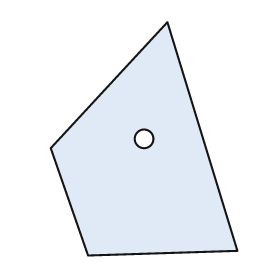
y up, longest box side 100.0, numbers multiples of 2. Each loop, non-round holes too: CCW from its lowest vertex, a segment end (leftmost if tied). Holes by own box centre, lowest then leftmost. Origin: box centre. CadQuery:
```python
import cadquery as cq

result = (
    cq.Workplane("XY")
    .moveTo(-24.0, -50.0)
    .lineTo(40.0, -48.0)
    .lineTo(10.0, 50.0)
    .lineTo(-40.0, -4.0)
    .close()
    .moveTo(0.0, 0.0)
    .circle(4.0)
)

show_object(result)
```